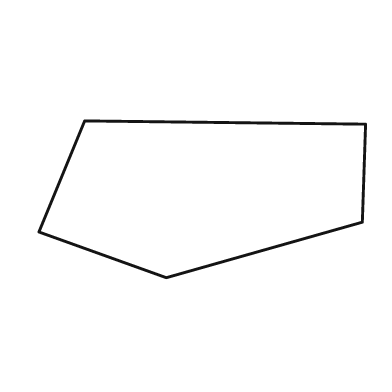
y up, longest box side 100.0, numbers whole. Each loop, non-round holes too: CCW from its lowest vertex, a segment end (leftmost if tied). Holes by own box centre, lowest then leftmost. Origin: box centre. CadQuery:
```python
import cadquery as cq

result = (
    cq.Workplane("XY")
    .moveTo(-11.0, -24.0)
    .lineTo(49.0, -7.0)
    .lineTo(50.0, 23.0)
    .lineTo(-36.0, 24.0)
    .lineTo(-50.0, -10.0)
    .close()
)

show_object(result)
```